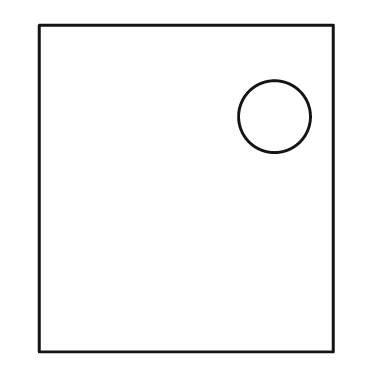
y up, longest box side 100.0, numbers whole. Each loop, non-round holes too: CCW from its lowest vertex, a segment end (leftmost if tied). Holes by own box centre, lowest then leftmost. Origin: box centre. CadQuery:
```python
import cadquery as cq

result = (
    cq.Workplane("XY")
    .moveTo(-45.0, -50.0)
    .lineTo(45.0, -50.0)
    .lineTo(45.0, 50.0)
    .lineTo(-45.0, 50.0)
    .close()
    .moveTo(27.0, 22.0)
    .circle(11.0)
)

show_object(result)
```